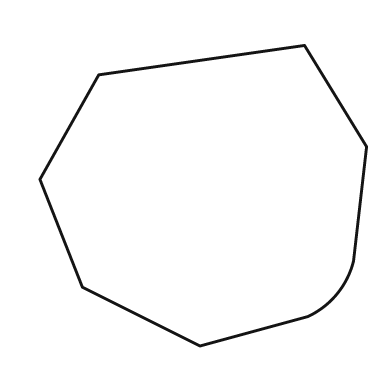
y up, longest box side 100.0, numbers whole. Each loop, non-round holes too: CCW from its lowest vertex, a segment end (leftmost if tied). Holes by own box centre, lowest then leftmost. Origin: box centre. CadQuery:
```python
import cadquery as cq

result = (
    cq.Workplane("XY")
    .moveTo(-1.0, -46.0)
    .lineTo(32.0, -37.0)
    .threePointArc((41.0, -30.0), (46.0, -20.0))
    .lineTo(50.0, 15.0)
    .lineTo(31.0, 46.0)
    .lineTo(-32.0, 37.0)
    .lineTo(-50.0, 5.0)
    .lineTo(-37.0, -28.0)
    .close()
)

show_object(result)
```